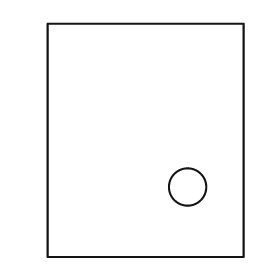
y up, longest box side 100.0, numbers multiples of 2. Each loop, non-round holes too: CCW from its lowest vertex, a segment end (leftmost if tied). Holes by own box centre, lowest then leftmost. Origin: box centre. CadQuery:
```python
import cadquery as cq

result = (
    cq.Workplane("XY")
    .moveTo(-42.0, -50.0)
    .lineTo(42.0, -50.0)
    .lineTo(42.0, 50.0)
    .lineTo(-42.0, 50.0)
    .close()
    .moveTo(18.0, -20.0)
    .circle(8.0)
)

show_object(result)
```